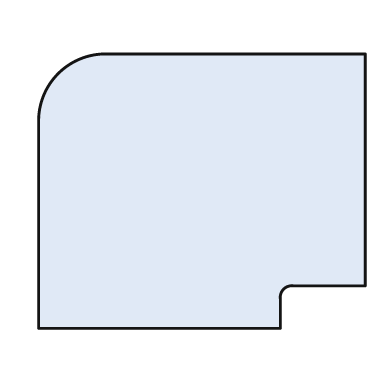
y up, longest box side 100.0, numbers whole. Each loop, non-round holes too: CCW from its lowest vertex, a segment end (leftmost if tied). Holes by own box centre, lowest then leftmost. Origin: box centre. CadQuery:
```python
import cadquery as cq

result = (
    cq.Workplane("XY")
    .moveTo(-50.0, -42.0)
    .lineTo(24.0, -42.0)
    .lineTo(24.0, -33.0)
    .threePointArc((25.0, -30.0), (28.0, -29.0))
    .lineTo(50.0, -29.0)
    .lineTo(50.0, 42.0)
    .lineTo(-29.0, 42.0)
    .threePointArc((-44.0, 36.0), (-50.0, 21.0))
    .close()
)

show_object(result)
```